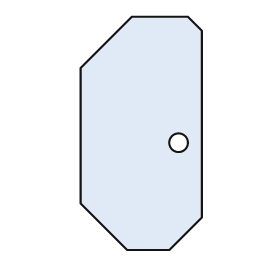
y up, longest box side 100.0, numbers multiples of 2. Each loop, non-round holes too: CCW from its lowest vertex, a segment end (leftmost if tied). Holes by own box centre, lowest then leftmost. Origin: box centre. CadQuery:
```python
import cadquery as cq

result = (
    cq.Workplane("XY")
    .moveTo(-6.0, -50.0)
    .lineTo(12.0, -50.0)
    .lineTo(26.0, -36.0)
    .lineTo(26.0, 44.0)
    .lineTo(20.0, 50.0)
    .lineTo(-4.0, 50.0)
    .lineTo(-26.0, 28.0)
    .lineTo(-26.0, -30.0)
    .close()
    .moveTo(16.0, -4.0)
    .circle(4.0)
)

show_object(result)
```